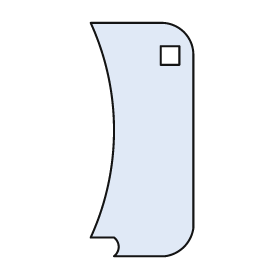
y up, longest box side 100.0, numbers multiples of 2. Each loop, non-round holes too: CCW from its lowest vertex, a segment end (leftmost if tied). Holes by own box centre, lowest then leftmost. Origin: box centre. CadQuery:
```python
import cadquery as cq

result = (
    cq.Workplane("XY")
    .moveTo(-12.0, -50.0)
    .lineTo(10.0, -50.0)
    .threePointArc((18.0, -46.0), (22.0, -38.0))
    .lineTo(22.0, 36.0)
    .threePointArc((18.0, 46.0), (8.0, 50.0))
    .lineTo(-22.0, 50.0)
    .threePointArc((-12.0, 4.0), (-22.0, -42.0))
    .lineTo(-12.0, -42.0)
    .threePointArc((-10.0, -46.0), (-12.0, -50.0))
    .close()
    .moveTo(8.0, 32.0)
    .lineTo(16.0, 32.0)
    .lineTo(16.0, 40.0)
    .lineTo(8.0, 40.0)
    .close()
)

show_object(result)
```